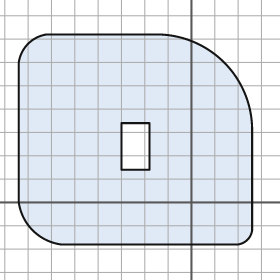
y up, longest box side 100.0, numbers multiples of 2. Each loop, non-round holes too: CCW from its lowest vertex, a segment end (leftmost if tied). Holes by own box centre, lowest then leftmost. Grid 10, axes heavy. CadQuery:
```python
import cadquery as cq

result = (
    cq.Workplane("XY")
    .moveTo(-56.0, -18.0)
    .lineTo(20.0, -18.0)
    .threePointArc((24.0, -16.0), (26.0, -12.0))
    .lineTo(26.0, 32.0)
    .threePointArc((14.0, 60.0), (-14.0, 72.0))
    .lineTo(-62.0, 72.0)
    .threePointArc((-70.0, 68.0), (-74.0, 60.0))
    .lineTo(-74.0, 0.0)
    .threePointArc((-68.0, -12.0), (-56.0, -18.0))
    .close()
    .moveTo(-30.0, 14.0)
    .lineTo(-18.0, 14.0)
    .lineTo(-18.0, 34.0)
    .lineTo(-30.0, 34.0)
    .close()
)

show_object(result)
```